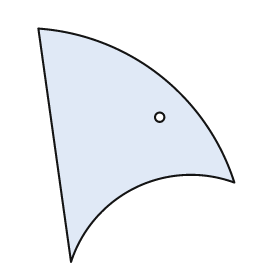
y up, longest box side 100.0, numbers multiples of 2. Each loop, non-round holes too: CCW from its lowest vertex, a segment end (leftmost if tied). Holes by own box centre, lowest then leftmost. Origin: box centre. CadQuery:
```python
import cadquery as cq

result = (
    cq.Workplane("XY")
    .moveTo(-28.0, -50.0)
    .threePointArc((0.0, -18.0), (42.0, -16.0))
    .threePointArc((10.0, 30.0), (-42.0, 50.0))
    .close()
    .moveTo(10.0, 12.0)
    .circle(2.0)
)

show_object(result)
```